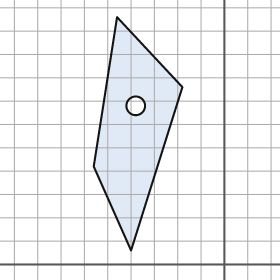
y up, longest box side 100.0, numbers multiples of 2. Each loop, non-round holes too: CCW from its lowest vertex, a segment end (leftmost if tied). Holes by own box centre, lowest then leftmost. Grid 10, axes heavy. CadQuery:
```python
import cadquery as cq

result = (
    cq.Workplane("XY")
    .moveTo(-40.0, 6.0)
    .lineTo(-18.0, 76.0)
    .lineTo(-46.0, 106.0)
    .lineTo(-56.0, 42.0)
    .close()
    .moveTo(-38.0, 68.0)
    .circle(4.0)
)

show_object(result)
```